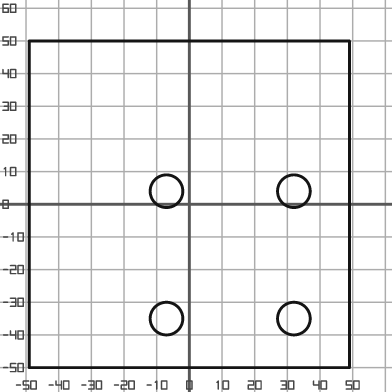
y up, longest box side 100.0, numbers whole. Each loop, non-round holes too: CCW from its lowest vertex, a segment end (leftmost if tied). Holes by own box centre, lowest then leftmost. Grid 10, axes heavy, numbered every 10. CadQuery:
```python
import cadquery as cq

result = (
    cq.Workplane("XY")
    .moveTo(-49.0, -50.0)
    .lineTo(49.0, -50.0)
    .lineTo(49.0, 50.0)
    .lineTo(-49.0, 50.0)
    .close()
    .moveTo(-7.0, -35.0)
    .circle(5.0)
    .moveTo(32.0, -35.0)
    .circle(5.0)
    .moveTo(-7.0, 4.0)
    .circle(5.0)
    .moveTo(32.0, 4.0)
    .circle(5.0)
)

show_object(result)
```